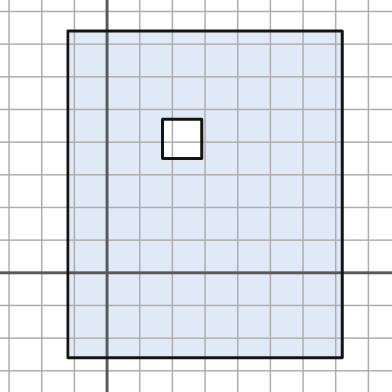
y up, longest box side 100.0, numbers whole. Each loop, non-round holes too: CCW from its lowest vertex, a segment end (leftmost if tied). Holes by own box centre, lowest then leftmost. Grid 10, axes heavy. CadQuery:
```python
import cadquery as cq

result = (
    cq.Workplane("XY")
    .moveTo(-12.0, -26.0)
    .lineTo(72.0, -26.0)
    .lineTo(72.0, 74.0)
    .lineTo(-12.0, 74.0)
    .close()
    .moveTo(17.0, 35.0)
    .lineTo(29.0, 35.0)
    .lineTo(29.0, 47.0)
    .lineTo(17.0, 47.0)
    .close()
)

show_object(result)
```